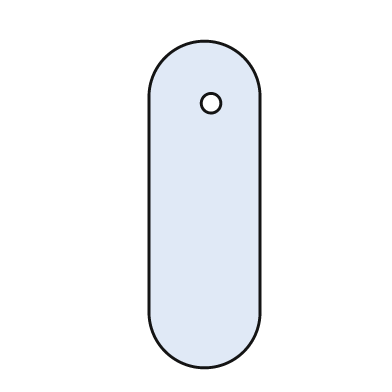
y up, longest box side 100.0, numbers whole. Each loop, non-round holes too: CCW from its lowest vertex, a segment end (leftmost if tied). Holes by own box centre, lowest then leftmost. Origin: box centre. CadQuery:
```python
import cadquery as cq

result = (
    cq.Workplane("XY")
    .moveTo(-17.0, -33.0)
    .threePointArc((0.0, -50.0), (17.0, -33.0))
    .lineTo(17.0, 33.0)
    .threePointArc((0.0, 50.0), (-17.0, 33.0))
    .close()
    .moveTo(2.0, 31.0)
    .circle(3.0)
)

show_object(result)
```